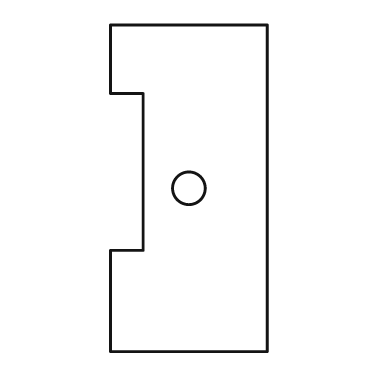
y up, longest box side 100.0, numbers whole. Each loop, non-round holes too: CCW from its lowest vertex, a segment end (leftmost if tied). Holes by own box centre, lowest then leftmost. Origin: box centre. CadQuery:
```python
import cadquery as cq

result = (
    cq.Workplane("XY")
    .moveTo(-24.0, -50.0)
    .lineTo(24.0, -50.0)
    .lineTo(24.0, 50.0)
    .lineTo(-24.0, 50.0)
    .lineTo(-24.0, 29.0)
    .lineTo(-14.0, 29.0)
    .lineTo(-14.0, -19.0)
    .lineTo(-24.0, -19.0)
    .close()
    .moveTo(0.0, 0.0)
    .circle(5.0)
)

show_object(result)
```